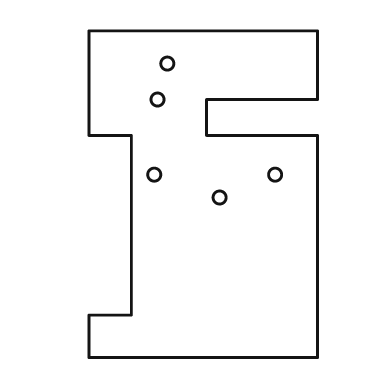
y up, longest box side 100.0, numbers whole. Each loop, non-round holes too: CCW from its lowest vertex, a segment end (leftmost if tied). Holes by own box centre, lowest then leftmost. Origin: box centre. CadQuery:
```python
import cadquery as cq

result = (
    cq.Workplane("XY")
    .moveTo(-35.0, -50.0)
    .lineTo(35.0, -50.0)
    .lineTo(35.0, 18.0)
    .lineTo(1.0, 18.0)
    .lineTo(1.0, 29.0)
    .lineTo(35.0, 29.0)
    .lineTo(35.0, 50.0)
    .lineTo(-35.0, 50.0)
    .lineTo(-35.0, 18.0)
    .lineTo(-22.0, 18.0)
    .lineTo(-22.0, -37.0)
    .lineTo(-35.0, -37.0)
    .close()
    .moveTo(5.0, -1.0)
    .circle(2.0)
    .moveTo(-15.0, 6.0)
    .circle(2.0)
    .moveTo(22.0, 6.0)
    .circle(2.0)
    .moveTo(-14.0, 29.0)
    .circle(2.0)
    .moveTo(-11.0, 40.0)
    .circle(2.0)
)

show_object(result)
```